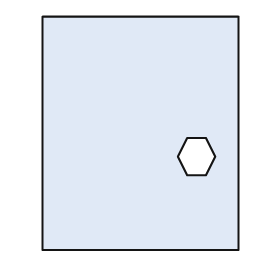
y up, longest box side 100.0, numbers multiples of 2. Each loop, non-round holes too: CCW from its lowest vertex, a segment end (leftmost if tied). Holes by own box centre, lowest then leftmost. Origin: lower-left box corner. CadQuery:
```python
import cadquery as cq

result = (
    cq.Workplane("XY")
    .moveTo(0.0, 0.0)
    .lineTo(84.0, 0.0)
    .lineTo(84.0, 100.0)
    .lineTo(0.0, 100.0)
    .close()
    .moveTo(62.0, 32.0)
    .lineTo(70.0, 32.0)
    .lineTo(74.0, 40.0)
    .lineTo(70.0, 48.0)
    .lineTo(62.0, 48.0)
    .lineTo(58.0, 40.0)
    .close()
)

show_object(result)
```